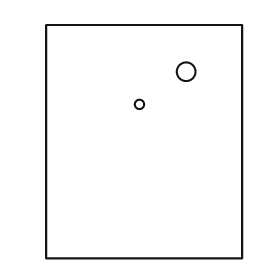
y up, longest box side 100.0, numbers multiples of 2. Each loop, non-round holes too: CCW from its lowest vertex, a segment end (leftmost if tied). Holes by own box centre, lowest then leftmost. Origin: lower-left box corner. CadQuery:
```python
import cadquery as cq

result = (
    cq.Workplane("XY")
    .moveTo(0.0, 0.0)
    .lineTo(84.0, 0.0)
    .lineTo(84.0, 100.0)
    .lineTo(0.0, 100.0)
    .close()
    .moveTo(40.0, 66.0)
    .circle(2.0)
    .moveTo(60.0, 80.0)
    .circle(4.0)
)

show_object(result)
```